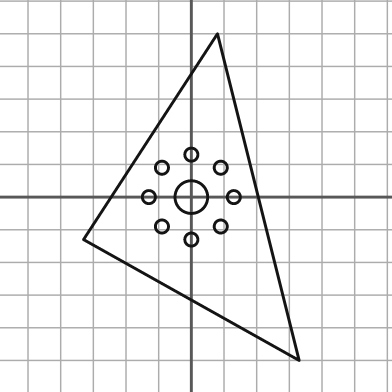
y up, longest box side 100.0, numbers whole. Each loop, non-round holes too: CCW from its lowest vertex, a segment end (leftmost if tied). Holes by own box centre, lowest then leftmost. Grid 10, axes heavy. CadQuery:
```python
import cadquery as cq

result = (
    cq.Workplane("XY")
    .moveTo(33.0, -50.0)
    .lineTo(8.0, 50.0)
    .lineTo(-33.0, -13.0)
    .close()
    .moveTo(0.0, -13.0)
    .circle(2.0)
    .moveTo(-9.0, -9.0)
    .circle(2.0)
    .moveTo(9.0, -9.0)
    .circle(2.0)
    .moveTo(-13.0, 0.0)
    .circle(2.0)
    .moveTo(0.0, 0.0)
    .circle(5.0)
    .moveTo(13.0, 0.0)
    .circle(2.0)
    .moveTo(-9.0, 9.0)
    .circle(2.0)
    .moveTo(9.0, 9.0)
    .circle(2.0)
    .moveTo(0.0, 13.0)
    .circle(2.0)
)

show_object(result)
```